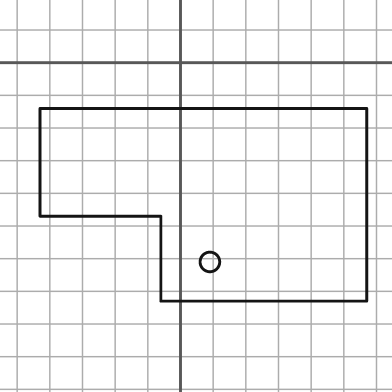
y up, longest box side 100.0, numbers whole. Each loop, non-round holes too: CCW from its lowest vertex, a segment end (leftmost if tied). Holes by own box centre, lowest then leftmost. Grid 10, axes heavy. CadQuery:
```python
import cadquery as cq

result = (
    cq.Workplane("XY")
    .moveTo(-6.0, -73.0)
    .lineTo(57.0, -73.0)
    .lineTo(57.0, -14.0)
    .lineTo(-43.0, -14.0)
    .lineTo(-43.0, -47.0)
    .lineTo(-6.0, -47.0)
    .close()
    .moveTo(9.0, -61.0)
    .circle(3.0)
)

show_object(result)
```